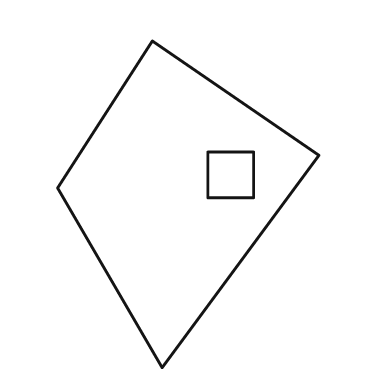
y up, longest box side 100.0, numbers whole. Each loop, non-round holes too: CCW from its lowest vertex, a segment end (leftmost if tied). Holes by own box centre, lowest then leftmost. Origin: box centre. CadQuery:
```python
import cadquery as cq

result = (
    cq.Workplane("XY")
    .moveTo(-8.0, -50.0)
    .lineTo(40.0, 15.0)
    .lineTo(-11.0, 50.0)
    .lineTo(-40.0, 5.0)
    .close()
    .moveTo(6.0, 2.0)
    .lineTo(20.0, 2.0)
    .lineTo(20.0, 16.0)
    .lineTo(6.0, 16.0)
    .close()
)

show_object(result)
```